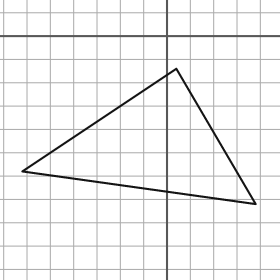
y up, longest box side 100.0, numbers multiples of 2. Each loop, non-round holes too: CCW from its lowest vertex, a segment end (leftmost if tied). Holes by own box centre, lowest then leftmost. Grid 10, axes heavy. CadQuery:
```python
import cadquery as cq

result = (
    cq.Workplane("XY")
    .moveTo(38.0, -72.0)
    .lineTo(4.0, -14.0)
    .lineTo(-62.0, -58.0)
    .close()
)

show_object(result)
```